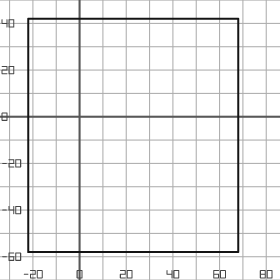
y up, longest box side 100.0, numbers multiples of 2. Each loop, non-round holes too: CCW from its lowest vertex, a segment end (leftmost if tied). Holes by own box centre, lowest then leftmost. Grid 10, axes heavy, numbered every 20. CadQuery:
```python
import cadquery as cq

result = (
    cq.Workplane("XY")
    .moveTo(-22.0, -58.0)
    .lineTo(68.0, -58.0)
    .lineTo(68.0, 42.0)
    .lineTo(-22.0, 42.0)
    .close()
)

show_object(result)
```